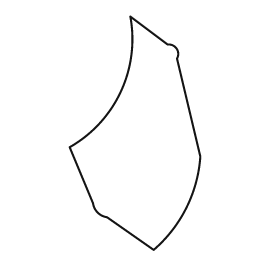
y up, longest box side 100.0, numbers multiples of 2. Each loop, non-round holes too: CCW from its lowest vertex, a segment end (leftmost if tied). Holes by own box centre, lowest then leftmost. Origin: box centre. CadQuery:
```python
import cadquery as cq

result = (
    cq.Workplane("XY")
    .moveTo(8.0, -50.0)
    .threePointArc((22.0, -32.0), (28.0, -10.0))
    .lineTo(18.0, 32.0)
    .threePointArc((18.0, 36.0), (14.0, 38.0))
    .lineTo(-2.0, 50.0)
    .threePointArc((-6.0, 18.0), (-28.0, -6.0))
    .lineTo(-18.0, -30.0)
    .threePointArc((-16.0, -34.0), (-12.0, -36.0))
    .close()
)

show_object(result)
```